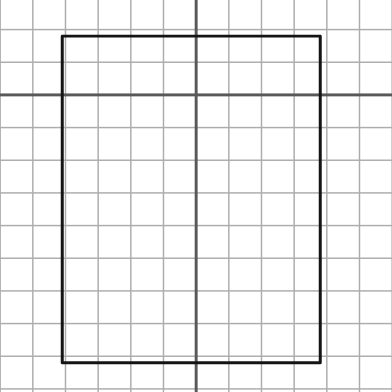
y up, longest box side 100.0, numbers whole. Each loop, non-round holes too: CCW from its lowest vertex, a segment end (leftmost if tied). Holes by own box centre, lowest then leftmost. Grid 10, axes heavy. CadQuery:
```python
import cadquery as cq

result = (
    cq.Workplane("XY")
    .moveTo(-41.0, -82.0)
    .lineTo(38.0, -82.0)
    .lineTo(38.0, 18.0)
    .lineTo(-41.0, 18.0)
    .close()
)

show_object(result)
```